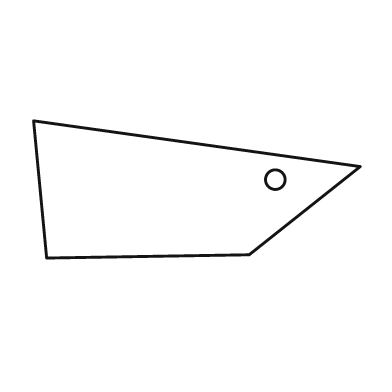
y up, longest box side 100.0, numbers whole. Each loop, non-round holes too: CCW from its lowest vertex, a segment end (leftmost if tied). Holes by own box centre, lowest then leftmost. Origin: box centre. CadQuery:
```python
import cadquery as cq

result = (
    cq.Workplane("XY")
    .moveTo(-46.0, -21.0)
    .lineTo(16.0, -20.0)
    .lineTo(50.0, 7.0)
    .lineTo(-50.0, 21.0)
    .close()
    .moveTo(24.0, 3.0)
    .circle(3.0)
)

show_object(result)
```